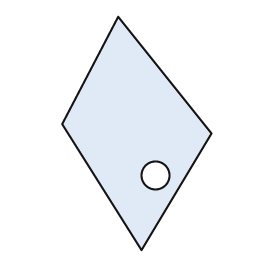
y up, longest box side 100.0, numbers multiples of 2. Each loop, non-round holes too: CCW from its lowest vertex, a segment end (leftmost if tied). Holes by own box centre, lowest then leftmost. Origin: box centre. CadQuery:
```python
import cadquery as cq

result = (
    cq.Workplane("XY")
    .moveTo(2.0, -50.0)
    .lineTo(32.0, 0.0)
    .lineTo(-8.0, 50.0)
    .lineTo(-32.0, 4.0)
    .close()
    .moveTo(8.0, -18.0)
    .circle(6.0)
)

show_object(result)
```